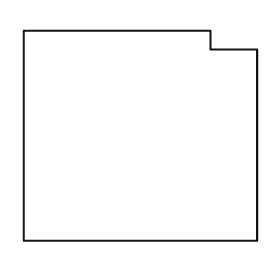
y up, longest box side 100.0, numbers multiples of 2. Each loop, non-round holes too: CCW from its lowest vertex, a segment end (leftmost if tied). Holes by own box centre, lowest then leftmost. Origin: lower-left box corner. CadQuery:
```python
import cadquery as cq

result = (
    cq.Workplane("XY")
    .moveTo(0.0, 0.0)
    .lineTo(100.0, 0.0)
    .lineTo(100.0, 82.0)
    .lineTo(80.0, 82.0)
    .lineTo(80.0, 90.0)
    .lineTo(0.0, 90.0)
    .close()
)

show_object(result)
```